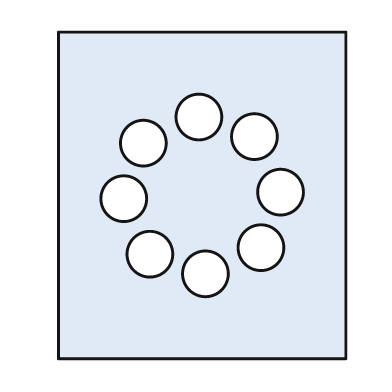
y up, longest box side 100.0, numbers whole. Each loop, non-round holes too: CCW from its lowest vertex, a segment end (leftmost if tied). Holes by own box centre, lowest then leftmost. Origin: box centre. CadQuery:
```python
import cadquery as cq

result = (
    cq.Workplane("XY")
    .moveTo(-44.0, -50.0)
    .lineTo(44.0, -50.0)
    .lineTo(44.0, 50.0)
    .lineTo(-44.0, 50.0)
    .close()
    .moveTo(1.0, -24.0)
    .circle(7.0)
    .moveTo(-16.0, -18.0)
    .circle(7.0)
    .moveTo(18.0, -16.0)
    .circle(7.0)
    .moveTo(-24.0, -1.0)
    .circle(7.0)
    .moveTo(24.0, 1.0)
    .circle(7.0)
    .moveTo(-18.0, 16.0)
    .circle(7.0)
    .moveTo(16.0, 18.0)
    .circle(7.0)
    .moveTo(-1.0, 24.0)
    .circle(7.0)
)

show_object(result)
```